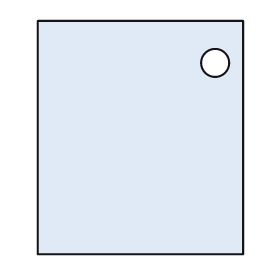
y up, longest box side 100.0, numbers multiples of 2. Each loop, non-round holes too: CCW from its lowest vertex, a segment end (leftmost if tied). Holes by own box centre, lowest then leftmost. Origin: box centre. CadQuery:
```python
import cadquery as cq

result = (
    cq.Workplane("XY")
    .moveTo(-44.0, -50.0)
    .lineTo(44.0, -50.0)
    .lineTo(44.0, 50.0)
    .lineTo(-44.0, 50.0)
    .close()
    .moveTo(32.0, 32.0)
    .circle(6.0)
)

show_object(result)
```